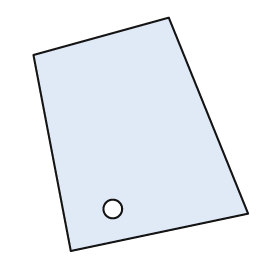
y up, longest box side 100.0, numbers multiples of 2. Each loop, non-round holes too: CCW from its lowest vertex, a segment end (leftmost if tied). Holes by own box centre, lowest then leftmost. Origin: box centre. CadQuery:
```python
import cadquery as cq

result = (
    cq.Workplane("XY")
    .moveTo(-30.0, -50.0)
    .lineTo(46.0, -34.0)
    .lineTo(12.0, 50.0)
    .lineTo(-46.0, 34.0)
    .close()
    .moveTo(-12.0, -32.0)
    .circle(4.0)
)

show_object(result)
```